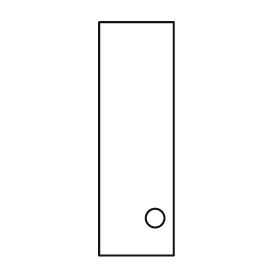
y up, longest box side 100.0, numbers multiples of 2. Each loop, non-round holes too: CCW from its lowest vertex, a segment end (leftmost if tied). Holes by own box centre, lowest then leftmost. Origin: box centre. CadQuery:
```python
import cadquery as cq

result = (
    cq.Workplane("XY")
    .moveTo(-16.0, -50.0)
    .lineTo(16.0, -50.0)
    .lineTo(16.0, 50.0)
    .lineTo(-16.0, 50.0)
    .close()
    .moveTo(8.0, -34.0)
    .circle(4.0)
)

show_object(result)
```